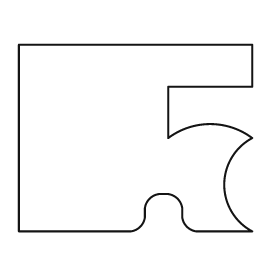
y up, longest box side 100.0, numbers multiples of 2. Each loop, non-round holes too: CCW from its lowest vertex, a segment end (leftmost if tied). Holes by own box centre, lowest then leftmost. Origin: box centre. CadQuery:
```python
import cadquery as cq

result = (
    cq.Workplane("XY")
    .moveTo(-50.0, -40.0)
    .lineTo(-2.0, -40.0)
    .threePointArc((2.0, -38.0), (4.0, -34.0))
    .lineTo(4.0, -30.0)
    .threePointArc((6.0, -26.0), (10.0, -24.0))
    .lineTo(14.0, -24.0)
    .threePointArc((18.0, -26.0), (20.0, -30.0))
    .lineTo(20.0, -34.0)
    .threePointArc((22.0, -38.0), (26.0, -40.0))
    .lineTo(50.0, -40.0)
    .threePointArc((38.0, -20.0), (50.0, 0.0))
    .threePointArc((32.0, 6.0), (14.0, 0.0))
    .lineTo(14.0, 22.0)
    .lineTo(50.0, 22.0)
    .lineTo(50.0, 40.0)
    .lineTo(-50.0, 40.0)
    .close()
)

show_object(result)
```